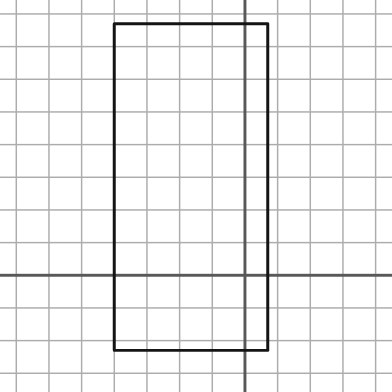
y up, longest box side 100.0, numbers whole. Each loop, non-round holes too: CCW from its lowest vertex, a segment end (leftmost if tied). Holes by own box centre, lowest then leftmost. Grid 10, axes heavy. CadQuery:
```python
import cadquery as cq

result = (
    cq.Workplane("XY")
    .moveTo(-40.0, -23.0)
    .lineTo(7.0, -23.0)
    .lineTo(7.0, 77.0)
    .lineTo(-40.0, 77.0)
    .close()
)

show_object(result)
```